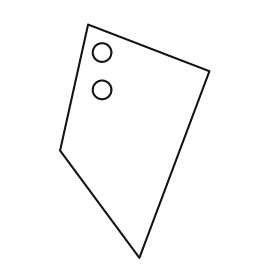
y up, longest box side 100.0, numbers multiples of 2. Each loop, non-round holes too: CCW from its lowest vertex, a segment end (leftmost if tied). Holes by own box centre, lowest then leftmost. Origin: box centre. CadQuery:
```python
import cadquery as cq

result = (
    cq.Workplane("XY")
    .moveTo(2.0, -50.0)
    .lineTo(32.0, 30.0)
    .lineTo(-20.0, 50.0)
    .lineTo(-32.0, -4.0)
    .close()
    .moveTo(-14.0, 22.0)
    .circle(4.0)
    .moveTo(-14.0, 38.0)
    .circle(4.0)
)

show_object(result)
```